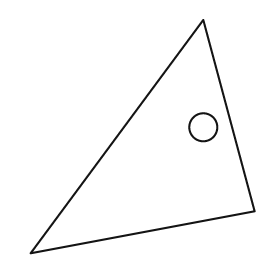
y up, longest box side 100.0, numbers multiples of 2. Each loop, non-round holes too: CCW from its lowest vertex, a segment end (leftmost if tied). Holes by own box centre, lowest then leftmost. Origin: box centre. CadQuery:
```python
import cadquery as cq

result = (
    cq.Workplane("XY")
    .moveTo(-48.0, -50.0)
    .lineTo(48.0, -32.0)
    .lineTo(26.0, 50.0)
    .close()
    .moveTo(26.0, 4.0)
    .circle(6.0)
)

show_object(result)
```